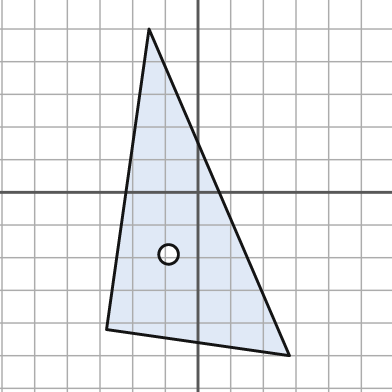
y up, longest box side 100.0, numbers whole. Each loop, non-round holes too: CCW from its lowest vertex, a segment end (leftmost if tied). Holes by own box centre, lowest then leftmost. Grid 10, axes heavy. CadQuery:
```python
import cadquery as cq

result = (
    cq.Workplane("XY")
    .moveTo(28.0, -50.0)
    .lineTo(-15.0, 50.0)
    .lineTo(-28.0, -42.0)
    .close()
    .moveTo(-9.0, -19.0)
    .circle(3.0)
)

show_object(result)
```